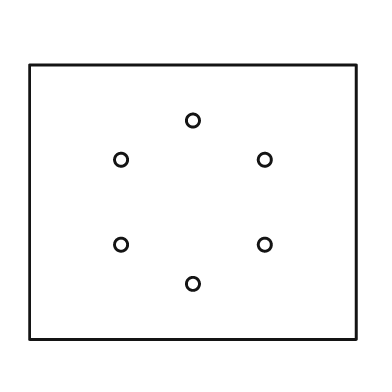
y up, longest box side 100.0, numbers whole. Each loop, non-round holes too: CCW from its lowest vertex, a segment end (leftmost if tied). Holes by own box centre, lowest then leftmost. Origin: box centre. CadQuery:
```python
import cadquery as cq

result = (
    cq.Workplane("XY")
    .moveTo(-50.0, -42.0)
    .lineTo(50.0, -42.0)
    .lineTo(50.0, 42.0)
    .lineTo(-50.0, 42.0)
    .close()
    .moveTo(0.0, -25.0)
    .circle(2.0)
    .moveTo(-22.0, -13.0)
    .circle(2.0)
    .moveTo(22.0, -13.0)
    .circle(2.0)
    .moveTo(-22.0, 13.0)
    .circle(2.0)
    .moveTo(22.0, 13.0)
    .circle(2.0)
    .moveTo(0.0, 25.0)
    .circle(2.0)
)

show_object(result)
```